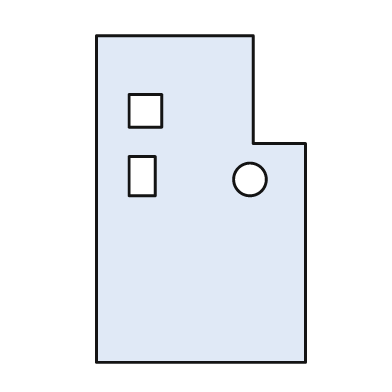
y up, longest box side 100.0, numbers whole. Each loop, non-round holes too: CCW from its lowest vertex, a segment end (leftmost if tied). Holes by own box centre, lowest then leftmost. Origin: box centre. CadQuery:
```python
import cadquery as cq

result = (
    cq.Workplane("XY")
    .moveTo(-32.0, -50.0)
    .lineTo(32.0, -50.0)
    .lineTo(32.0, 17.0)
    .lineTo(16.0, 17.0)
    .lineTo(16.0, 50.0)
    .lineTo(-32.0, 50.0)
    .close()
    .moveTo(15.0, 6.0)
    .circle(5.0)
    .moveTo(-22.0, 1.0)
    .lineTo(-14.0, 1.0)
    .lineTo(-14.0, 13.0)
    .lineTo(-22.0, 13.0)
    .close()
    .moveTo(-22.0, 22.0)
    .lineTo(-12.0, 22.0)
    .lineTo(-12.0, 32.0)
    .lineTo(-22.0, 32.0)
    .close()
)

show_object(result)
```